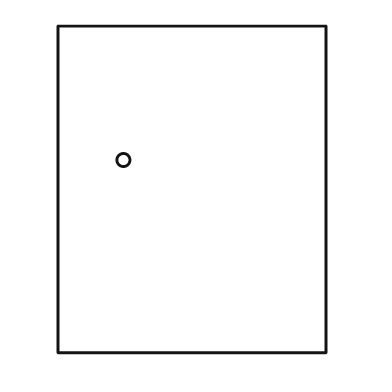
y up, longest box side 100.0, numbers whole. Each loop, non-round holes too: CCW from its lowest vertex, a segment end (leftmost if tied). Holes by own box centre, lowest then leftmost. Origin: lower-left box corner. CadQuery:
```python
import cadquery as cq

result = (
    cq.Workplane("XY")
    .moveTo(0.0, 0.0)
    .lineTo(82.0, 0.0)
    .lineTo(82.0, 100.0)
    .lineTo(0.0, 100.0)
    .close()
    .moveTo(20.0, 59.0)
    .circle(2.0)
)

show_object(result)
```